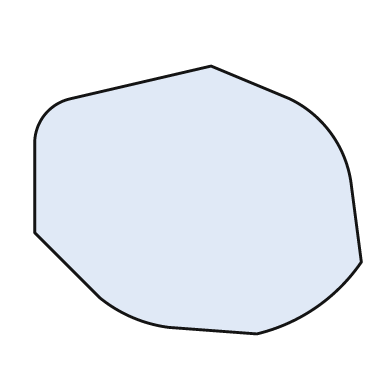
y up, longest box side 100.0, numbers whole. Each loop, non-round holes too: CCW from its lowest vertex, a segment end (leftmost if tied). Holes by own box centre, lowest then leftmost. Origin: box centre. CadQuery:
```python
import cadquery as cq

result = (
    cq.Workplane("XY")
    .moveTo(18.0, -41.0)
    .threePointArc((36.0, -33.0), (50.0, -19.0))
    .lineTo(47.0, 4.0)
    .threePointArc((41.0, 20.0), (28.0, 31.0))
    .lineTo(4.0, 41.0)
    .lineTo(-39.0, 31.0)
    .threePointArc((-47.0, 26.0), (-50.0, 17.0))
    .lineTo(-50.0, -10.0)
    .lineTo(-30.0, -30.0)
    .threePointArc((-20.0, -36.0), (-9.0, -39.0))
    .close()
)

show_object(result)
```